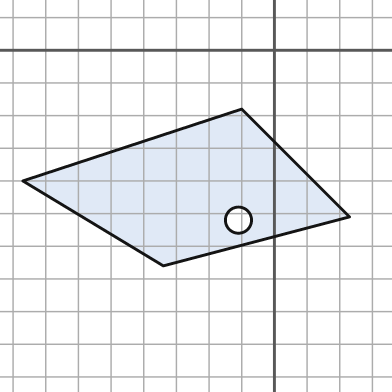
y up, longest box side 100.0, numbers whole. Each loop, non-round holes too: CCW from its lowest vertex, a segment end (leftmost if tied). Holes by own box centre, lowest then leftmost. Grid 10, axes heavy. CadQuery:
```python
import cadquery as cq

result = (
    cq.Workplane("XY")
    .moveTo(-34.0, -66.0)
    .lineTo(23.0, -51.0)
    .lineTo(-10.0, -18.0)
    .lineTo(-77.0, -40.0)
    .close()
    .moveTo(-11.0, -52.0)
    .circle(4.0)
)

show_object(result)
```